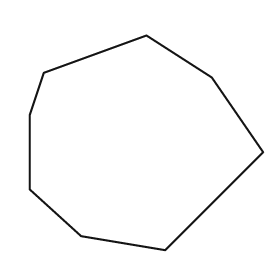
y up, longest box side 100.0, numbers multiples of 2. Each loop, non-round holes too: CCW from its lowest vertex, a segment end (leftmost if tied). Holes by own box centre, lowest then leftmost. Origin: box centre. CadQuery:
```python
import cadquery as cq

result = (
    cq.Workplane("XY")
    .moveTo(8.0, -46.0)
    .lineTo(50.0, -4.0)
    .lineTo(28.0, 28.0)
    .lineTo(0.0, 46.0)
    .lineTo(-44.0, 30.0)
    .lineTo(-50.0, 12.0)
    .lineTo(-50.0, -20.0)
    .lineTo(-28.0, -40.0)
    .close()
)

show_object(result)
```